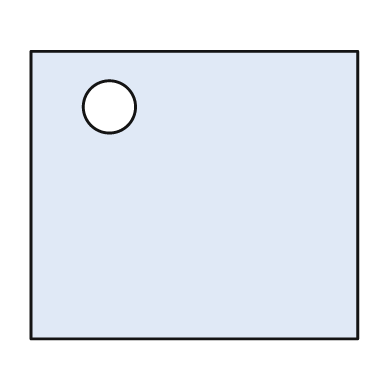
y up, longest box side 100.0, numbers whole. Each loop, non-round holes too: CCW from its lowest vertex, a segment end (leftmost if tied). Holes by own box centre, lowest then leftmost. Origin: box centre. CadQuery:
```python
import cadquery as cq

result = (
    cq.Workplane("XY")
    .moveTo(-50.0, -44.0)
    .lineTo(50.0, -44.0)
    .lineTo(50.0, 44.0)
    .lineTo(-50.0, 44.0)
    .close()
    .moveTo(-26.0, 27.0)
    .circle(8.0)
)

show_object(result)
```